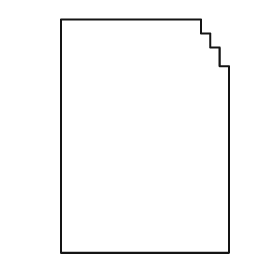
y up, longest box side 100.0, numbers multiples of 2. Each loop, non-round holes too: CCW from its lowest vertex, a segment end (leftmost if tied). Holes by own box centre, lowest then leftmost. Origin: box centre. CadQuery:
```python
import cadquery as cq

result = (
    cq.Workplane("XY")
    .moveTo(-36.0, -50.0)
    .lineTo(36.0, -50.0)
    .lineTo(36.0, 30.0)
    .lineTo(32.0, 30.0)
    .lineTo(32.0, 38.0)
    .lineTo(28.0, 38.0)
    .lineTo(28.0, 44.0)
    .lineTo(24.0, 44.0)
    .lineTo(24.0, 50.0)
    .lineTo(-36.0, 50.0)
    .close()
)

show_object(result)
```